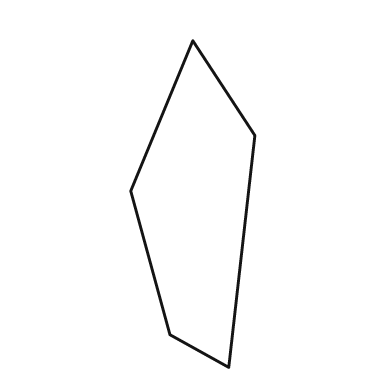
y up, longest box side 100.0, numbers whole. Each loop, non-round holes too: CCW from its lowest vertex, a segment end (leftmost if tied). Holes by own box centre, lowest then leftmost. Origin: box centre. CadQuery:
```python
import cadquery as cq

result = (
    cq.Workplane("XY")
    .moveTo(11.0, -50.0)
    .lineTo(19.0, 21.0)
    .lineTo(0.0, 50.0)
    .lineTo(-19.0, 4.0)
    .lineTo(-7.0, -40.0)
    .close()
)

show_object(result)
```